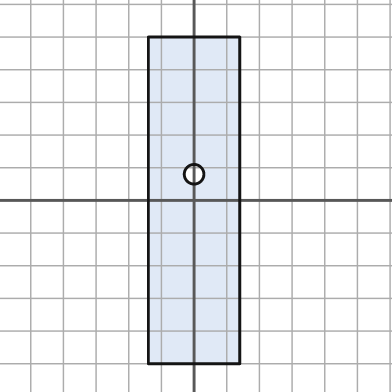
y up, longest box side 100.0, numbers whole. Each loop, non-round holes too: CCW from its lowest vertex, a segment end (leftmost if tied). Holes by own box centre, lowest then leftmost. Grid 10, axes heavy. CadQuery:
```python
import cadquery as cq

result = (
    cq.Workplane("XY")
    .moveTo(-14.0, -50.0)
    .lineTo(14.0, -50.0)
    .lineTo(14.0, 50.0)
    .lineTo(-14.0, 50.0)
    .close()
    .moveTo(0.0, 8.0)
    .circle(3.0)
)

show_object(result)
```